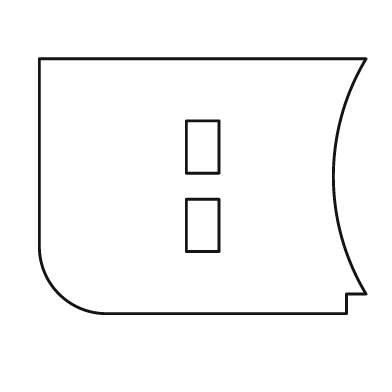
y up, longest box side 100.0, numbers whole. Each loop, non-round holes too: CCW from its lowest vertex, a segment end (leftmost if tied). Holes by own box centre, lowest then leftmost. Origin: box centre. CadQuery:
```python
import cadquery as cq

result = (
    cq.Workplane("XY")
    .moveTo(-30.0, -39.0)
    .lineTo(44.0, -39.0)
    .lineTo(44.0, -33.0)
    .lineTo(50.0, -33.0)
    .threePointArc((40.0, 3.0), (50.0, 39.0))
    .lineTo(-50.0, 39.0)
    .lineTo(-50.0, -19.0)
    .threePointArc((-44.0, -33.0), (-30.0, -39.0))
    .close()
    .moveTo(-5.0, -20.0)
    .lineTo(5.0, -20.0)
    .lineTo(5.0, -4.0)
    .lineTo(-5.0, -4.0)
    .close()
    .moveTo(-5.0, 4.0)
    .lineTo(5.0, 4.0)
    .lineTo(5.0, 20.0)
    .lineTo(-5.0, 20.0)
    .close()
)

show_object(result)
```